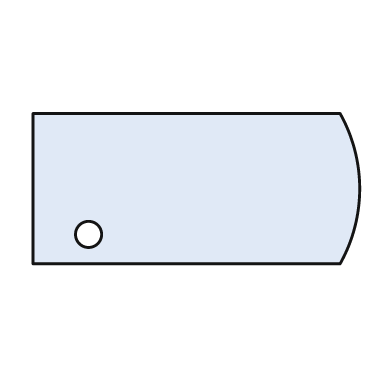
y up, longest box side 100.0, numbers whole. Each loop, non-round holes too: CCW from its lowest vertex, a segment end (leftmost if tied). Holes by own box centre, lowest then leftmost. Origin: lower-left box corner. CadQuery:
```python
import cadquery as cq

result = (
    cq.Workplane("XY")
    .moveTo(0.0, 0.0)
    .lineTo(94.0, 0.0)
    .threePointArc((100.0, 23.0), (94.0, 46.0))
    .lineTo(0.0, 46.0)
    .close()
    .moveTo(17.0, 9.0)
    .circle(4.0)
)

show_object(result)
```